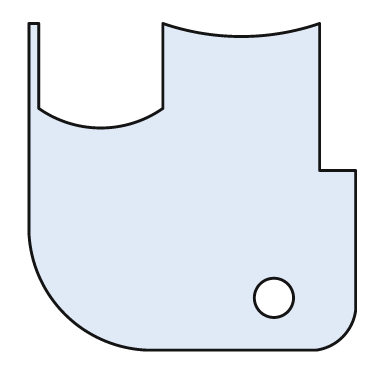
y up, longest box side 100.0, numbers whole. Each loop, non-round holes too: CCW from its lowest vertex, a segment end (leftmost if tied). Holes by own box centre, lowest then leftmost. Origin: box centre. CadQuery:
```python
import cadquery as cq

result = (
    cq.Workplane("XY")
    .moveTo(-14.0, -50.0)
    .lineTo(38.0, -50.0)
    .threePointArc((46.0, -46.0), (50.0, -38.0))
    .lineTo(50.0, 5.0)
    .lineTo(39.0, 5.0)
    .lineTo(39.0, 50.0)
    .threePointArc((15.0, 46.0), (-9.0, 50.0))
    .lineTo(-9.0, 24.0)
    .threePointArc((-28.0, 18.0), (-47.0, 24.0))
    .lineTo(-47.0, 50.0)
    .lineTo(-50.0, 50.0)
    .lineTo(-50.0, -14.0)
    .threePointArc((-39.0, -39.0), (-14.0, -50.0))
    .close()
    .moveTo(25.0, -34.0)
    .circle(6.0)
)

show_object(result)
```